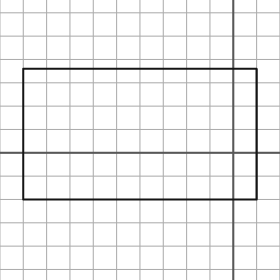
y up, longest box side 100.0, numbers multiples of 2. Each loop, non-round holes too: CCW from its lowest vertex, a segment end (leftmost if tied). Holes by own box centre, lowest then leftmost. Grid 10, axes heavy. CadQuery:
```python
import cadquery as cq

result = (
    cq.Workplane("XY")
    .moveTo(-90.0, -20.0)
    .lineTo(10.0, -20.0)
    .lineTo(10.0, 36.0)
    .lineTo(-90.0, 36.0)
    .close()
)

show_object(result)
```